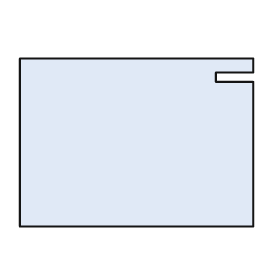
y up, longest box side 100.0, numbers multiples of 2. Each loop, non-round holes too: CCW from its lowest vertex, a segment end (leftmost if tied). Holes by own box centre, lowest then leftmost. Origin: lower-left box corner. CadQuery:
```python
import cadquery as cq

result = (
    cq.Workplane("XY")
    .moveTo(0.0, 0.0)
    .lineTo(100.0, 0.0)
    .lineTo(100.0, 62.0)
    .lineTo(84.0, 62.0)
    .lineTo(84.0, 66.0)
    .lineTo(100.0, 66.0)
    .lineTo(100.0, 72.0)
    .lineTo(0.0, 72.0)
    .close()
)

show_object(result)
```